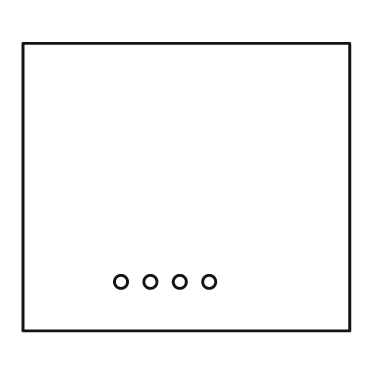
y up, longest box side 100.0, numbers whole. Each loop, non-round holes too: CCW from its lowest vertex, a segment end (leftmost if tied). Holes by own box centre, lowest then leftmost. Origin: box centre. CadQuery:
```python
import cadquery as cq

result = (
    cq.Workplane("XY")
    .moveTo(-50.0, -44.0)
    .lineTo(50.0, -44.0)
    .lineTo(50.0, 44.0)
    .lineTo(-50.0, 44.0)
    .close()
    .moveTo(-20.0, -29.0)
    .circle(2.0)
    .moveTo(-11.0, -29.0)
    .circle(2.0)
    .moveTo(-2.0, -29.0)
    .circle(2.0)
    .moveTo(7.0, -29.0)
    .circle(2.0)
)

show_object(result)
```